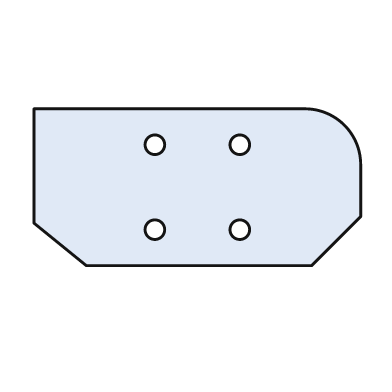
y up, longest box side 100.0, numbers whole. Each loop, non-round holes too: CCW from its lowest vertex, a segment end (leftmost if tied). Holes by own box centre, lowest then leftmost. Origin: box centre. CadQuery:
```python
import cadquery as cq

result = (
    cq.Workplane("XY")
    .moveTo(-34.0, -24.0)
    .lineTo(35.0, -24.0)
    .lineTo(50.0, -9.0)
    .lineTo(50.0, 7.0)
    .threePointArc((45.0, 19.0), (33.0, 24.0))
    .lineTo(-50.0, 24.0)
    .lineTo(-50.0, -11.0)
    .close()
    .moveTo(-13.0, -13.0)
    .circle(3.0)
    .moveTo(13.0, -13.0)
    .circle(3.0)
    .moveTo(-13.0, 13.0)
    .circle(3.0)
    .moveTo(13.0, 13.0)
    .circle(3.0)
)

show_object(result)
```